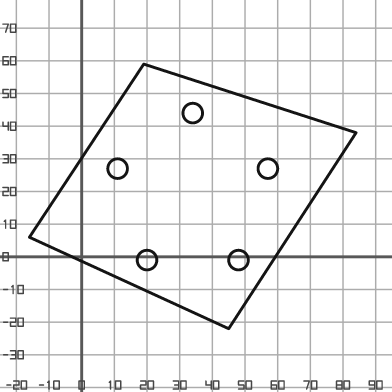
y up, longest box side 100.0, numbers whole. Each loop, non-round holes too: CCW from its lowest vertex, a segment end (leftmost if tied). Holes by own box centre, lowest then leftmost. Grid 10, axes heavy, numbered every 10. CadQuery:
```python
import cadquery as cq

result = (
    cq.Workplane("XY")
    .moveTo(45.0, -22.0)
    .lineTo(84.0, 38.0)
    .lineTo(19.0, 59.0)
    .lineTo(-16.0, 6.0)
    .close()
    .moveTo(20.0, -1.0)
    .circle(3.0)
    .moveTo(48.0, -1.0)
    .circle(3.0)
    .moveTo(11.0, 27.0)
    .circle(3.0)
    .moveTo(57.0, 27.0)
    .circle(3.0)
    .moveTo(34.0, 44.0)
    .circle(3.0)
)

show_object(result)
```